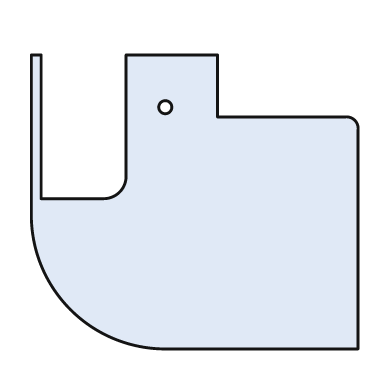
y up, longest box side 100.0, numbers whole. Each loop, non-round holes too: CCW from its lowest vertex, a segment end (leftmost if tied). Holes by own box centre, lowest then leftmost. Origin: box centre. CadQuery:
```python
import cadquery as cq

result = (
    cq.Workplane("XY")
    .moveTo(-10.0, -45.0)
    .lineTo(50.0, -45.0)
    .lineTo(50.0, 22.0)
    .threePointArc((49.0, 25.0), (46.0, 26.0))
    .lineTo(7.0, 26.0)
    .lineTo(7.0, 45.0)
    .lineTo(-21.0, 45.0)
    .lineTo(-21.0, 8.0)
    .threePointArc((-23.0, 3.0), (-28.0, 1.0))
    .lineTo(-47.0, 1.0)
    .lineTo(-47.0, 45.0)
    .lineTo(-50.0, 45.0)
    .lineTo(-50.0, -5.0)
    .threePointArc((-38.0, -33.0), (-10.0, -45.0))
    .close()
    .moveTo(-9.0, 29.0)
    .circle(2.0)
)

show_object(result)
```